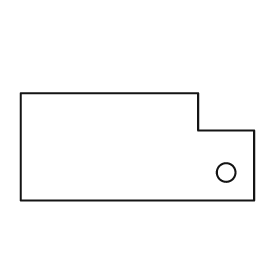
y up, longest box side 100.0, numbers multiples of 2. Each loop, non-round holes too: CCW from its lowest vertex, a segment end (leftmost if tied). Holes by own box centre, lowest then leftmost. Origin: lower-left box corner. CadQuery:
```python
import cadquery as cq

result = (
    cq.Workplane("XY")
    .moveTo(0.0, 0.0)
    .lineTo(100.0, 0.0)
    .lineTo(100.0, 30.0)
    .lineTo(76.0, 30.0)
    .lineTo(76.0, 46.0)
    .lineTo(0.0, 46.0)
    .close()
    .moveTo(88.0, 12.0)
    .circle(4.0)
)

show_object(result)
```